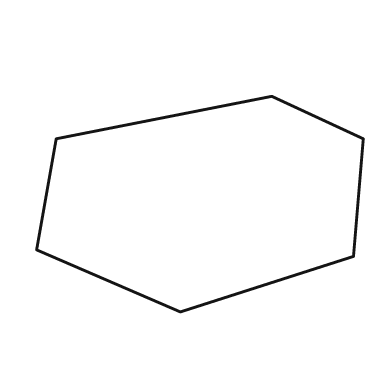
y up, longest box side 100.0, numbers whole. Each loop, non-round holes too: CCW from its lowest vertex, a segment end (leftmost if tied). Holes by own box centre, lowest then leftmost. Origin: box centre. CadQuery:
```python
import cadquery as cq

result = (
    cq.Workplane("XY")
    .moveTo(-6.0, -33.0)
    .lineTo(47.0, -16.0)
    .lineTo(50.0, 20.0)
    .lineTo(22.0, 33.0)
    .lineTo(-44.0, 20.0)
    .lineTo(-50.0, -14.0)
    .close()
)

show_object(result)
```